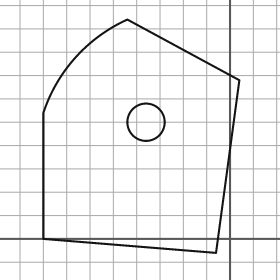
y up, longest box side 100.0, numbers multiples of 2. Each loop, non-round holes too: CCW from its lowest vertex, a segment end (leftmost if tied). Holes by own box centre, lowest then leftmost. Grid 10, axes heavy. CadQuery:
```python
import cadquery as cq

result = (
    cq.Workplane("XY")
    .moveTo(-6.0, -6.0)
    .lineTo(4.0, 68.0)
    .lineTo(-44.0, 94.0)
    .threePointArc((-66.0, 78.0), (-80.0, 54.0))
    .lineTo(-80.0, 0.0)
    .close()
    .moveTo(-36.0, 50.0)
    .circle(8.0)
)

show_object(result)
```